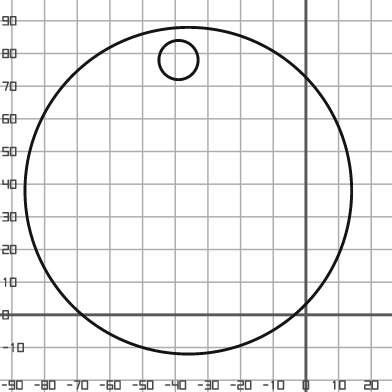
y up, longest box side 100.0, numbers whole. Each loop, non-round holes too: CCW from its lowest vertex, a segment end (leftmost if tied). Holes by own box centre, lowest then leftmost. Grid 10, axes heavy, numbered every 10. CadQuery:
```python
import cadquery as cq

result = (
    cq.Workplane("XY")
    .moveTo(-36.0, 38.0)
    .circle(50.0)
    .moveTo(-39.0, 78.0)
    .circle(6.0)
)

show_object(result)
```